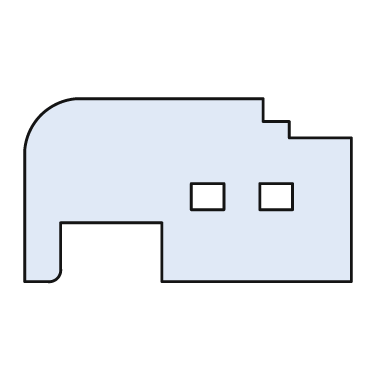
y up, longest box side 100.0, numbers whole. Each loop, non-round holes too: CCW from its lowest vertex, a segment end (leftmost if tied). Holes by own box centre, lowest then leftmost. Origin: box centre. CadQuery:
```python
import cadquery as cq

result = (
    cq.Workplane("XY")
    .moveTo(-50.0, -28.0)
    .lineTo(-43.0, -28.0)
    .threePointArc((-40.0, -27.0), (-39.0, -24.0))
    .lineTo(-39.0, -10.0)
    .lineTo(-8.0, -10.0)
    .lineTo(-8.0, -28.0)
    .lineTo(50.0, -28.0)
    .lineTo(50.0, 16.0)
    .lineTo(31.0, 16.0)
    .lineTo(31.0, 21.0)
    .lineTo(23.0, 21.0)
    .lineTo(23.0, 28.0)
    .lineTo(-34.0, 28.0)
    .threePointArc((-45.0, 23.0), (-50.0, 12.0))
    .close()
    .moveTo(1.0, -6.0)
    .lineTo(11.0, -6.0)
    .lineTo(11.0, 2.0)
    .lineTo(1.0, 2.0)
    .close()
    .moveTo(22.0, -6.0)
    .lineTo(32.0, -6.0)
    .lineTo(32.0, 2.0)
    .lineTo(22.0, 2.0)
    .close()
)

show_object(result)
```